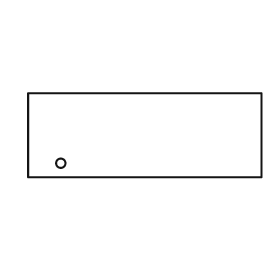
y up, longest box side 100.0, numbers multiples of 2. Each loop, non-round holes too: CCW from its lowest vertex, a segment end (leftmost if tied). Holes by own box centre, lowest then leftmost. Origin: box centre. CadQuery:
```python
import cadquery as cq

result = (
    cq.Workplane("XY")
    .moveTo(-50.0, -18.0)
    .lineTo(50.0, -18.0)
    .lineTo(50.0, 18.0)
    .lineTo(-50.0, 18.0)
    .close()
    .moveTo(-36.0, -12.0)
    .circle(2.0)
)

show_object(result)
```